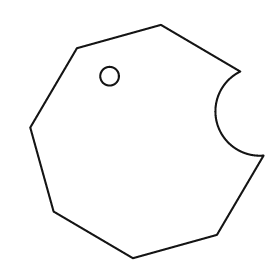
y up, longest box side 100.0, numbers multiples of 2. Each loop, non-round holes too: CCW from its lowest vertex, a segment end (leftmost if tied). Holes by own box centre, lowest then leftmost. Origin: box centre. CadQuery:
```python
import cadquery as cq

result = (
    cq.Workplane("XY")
    .moveTo(-6.0, -50.0)
    .lineTo(30.0, -40.0)
    .lineTo(50.0, -6.0)
    .threePointArc((30.0, 8.0), (40.0, 30.0))
    .lineTo(6.0, 50.0)
    .lineTo(-30.0, 40.0)
    .lineTo(-50.0, 6.0)
    .lineTo(-40.0, -30.0)
    .close()
    .moveTo(-16.0, 28.0)
    .circle(4.0)
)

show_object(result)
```